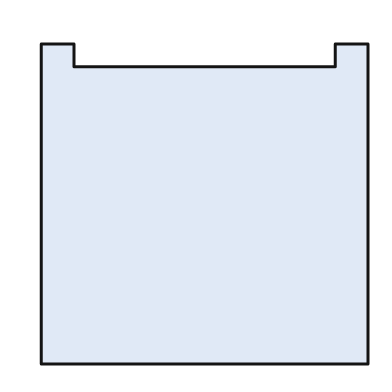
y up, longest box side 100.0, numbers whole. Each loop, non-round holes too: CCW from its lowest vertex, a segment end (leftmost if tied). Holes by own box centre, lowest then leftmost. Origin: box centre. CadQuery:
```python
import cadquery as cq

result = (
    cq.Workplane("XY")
    .moveTo(-50.0, -49.0)
    .lineTo(50.0, -49.0)
    .lineTo(50.0, 49.0)
    .lineTo(40.0, 49.0)
    .lineTo(40.0, 42.0)
    .lineTo(-40.0, 42.0)
    .lineTo(-40.0, 49.0)
    .lineTo(-50.0, 49.0)
    .close()
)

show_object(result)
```